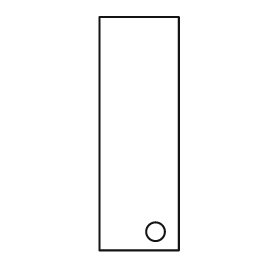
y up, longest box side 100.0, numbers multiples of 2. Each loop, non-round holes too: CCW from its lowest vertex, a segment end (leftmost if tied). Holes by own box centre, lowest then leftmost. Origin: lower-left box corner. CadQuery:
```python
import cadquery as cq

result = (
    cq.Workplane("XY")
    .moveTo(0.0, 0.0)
    .lineTo(34.0, 0.0)
    .lineTo(34.0, 100.0)
    .lineTo(0.0, 100.0)
    .close()
    .moveTo(24.0, 8.0)
    .circle(4.0)
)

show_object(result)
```